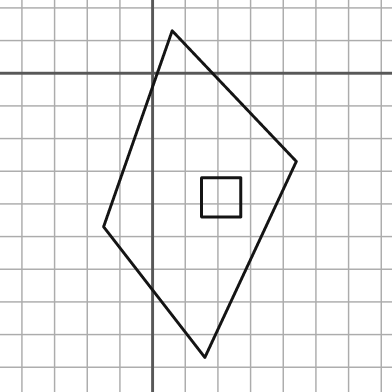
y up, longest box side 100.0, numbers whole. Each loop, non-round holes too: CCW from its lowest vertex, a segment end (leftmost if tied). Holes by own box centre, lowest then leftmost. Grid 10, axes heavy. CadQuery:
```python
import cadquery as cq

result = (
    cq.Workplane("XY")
    .moveTo(16.0, -87.0)
    .lineTo(44.0, -27.0)
    .lineTo(6.0, 13.0)
    .lineTo(-15.0, -47.0)
    .close()
    .moveTo(15.0, -44.0)
    .lineTo(27.0, -44.0)
    .lineTo(27.0, -32.0)
    .lineTo(15.0, -32.0)
    .close()
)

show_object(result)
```